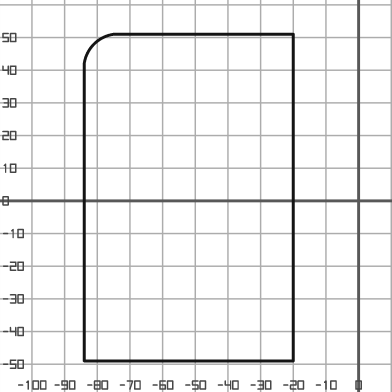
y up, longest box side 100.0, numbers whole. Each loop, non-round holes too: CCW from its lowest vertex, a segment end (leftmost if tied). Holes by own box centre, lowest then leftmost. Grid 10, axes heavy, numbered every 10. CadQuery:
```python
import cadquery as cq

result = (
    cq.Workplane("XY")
    .moveTo(-84.0, -49.0)
    .lineTo(-20.0, -49.0)
    .lineTo(-20.0, 51.0)
    .lineTo(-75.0, 51.0)
    .threePointArc((-81.0, 48.0), (-84.0, 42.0))
    .close()
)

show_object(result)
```